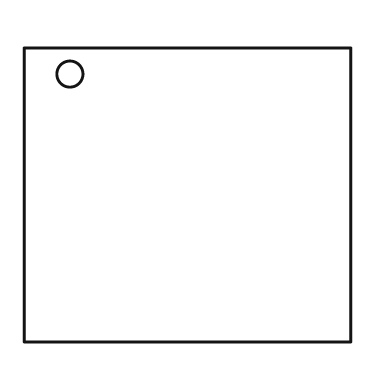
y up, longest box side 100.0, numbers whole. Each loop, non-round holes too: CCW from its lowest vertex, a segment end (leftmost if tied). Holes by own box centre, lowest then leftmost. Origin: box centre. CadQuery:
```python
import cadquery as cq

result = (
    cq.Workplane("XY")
    .moveTo(-50.0, -45.0)
    .lineTo(50.0, -45.0)
    .lineTo(50.0, 45.0)
    .lineTo(-50.0, 45.0)
    .close()
    .moveTo(-36.0, 37.0)
    .circle(4.0)
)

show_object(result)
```